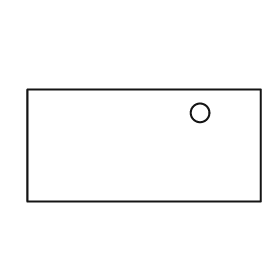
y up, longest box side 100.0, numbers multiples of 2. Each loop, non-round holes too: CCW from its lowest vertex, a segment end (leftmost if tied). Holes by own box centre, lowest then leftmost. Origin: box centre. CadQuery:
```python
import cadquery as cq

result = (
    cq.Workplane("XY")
    .moveTo(-50.0, -24.0)
    .lineTo(50.0, -24.0)
    .lineTo(50.0, 24.0)
    .lineTo(-50.0, 24.0)
    .close()
    .moveTo(24.0, 14.0)
    .circle(4.0)
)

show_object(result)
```